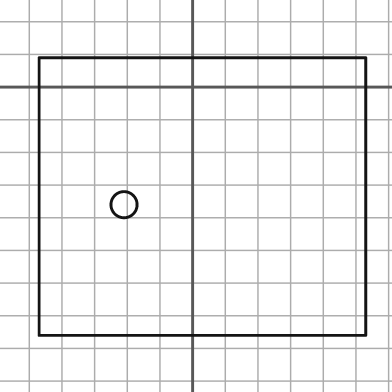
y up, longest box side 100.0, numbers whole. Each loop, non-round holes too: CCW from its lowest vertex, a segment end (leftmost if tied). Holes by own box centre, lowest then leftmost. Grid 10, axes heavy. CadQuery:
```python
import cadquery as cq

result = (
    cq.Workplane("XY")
    .moveTo(-47.0, -76.0)
    .lineTo(53.0, -76.0)
    .lineTo(53.0, 9.0)
    .lineTo(-47.0, 9.0)
    .close()
    .moveTo(-21.0, -36.0)
    .circle(4.0)
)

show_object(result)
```